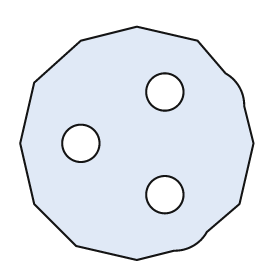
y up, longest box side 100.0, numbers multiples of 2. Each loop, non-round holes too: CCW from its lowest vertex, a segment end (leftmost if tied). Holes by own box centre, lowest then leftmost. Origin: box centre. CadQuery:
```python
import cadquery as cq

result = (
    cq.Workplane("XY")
    .moveTo(0.0, -50.0)
    .lineTo(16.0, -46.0)
    .threePointArc((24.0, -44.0), (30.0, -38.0))
    .lineTo(44.0, -26.0)
    .lineTo(50.0, 0.0)
    .lineTo(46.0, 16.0)
    .threePointArc((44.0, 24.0), (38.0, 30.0))
    .lineTo(26.0, 44.0)
    .lineTo(0.0, 50.0)
    .lineTo(-24.0, 44.0)
    .lineTo(-44.0, 26.0)
    .lineTo(-50.0, 0.0)
    .lineTo(-44.0, -26.0)
    .lineTo(-26.0, -44.0)
    .close()
    .moveTo(12.0, -22.0)
    .circle(8.0)
    .moveTo(-24.0, 0.0)
    .circle(8.0)
    .moveTo(12.0, 22.0)
    .circle(8.0)
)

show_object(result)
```